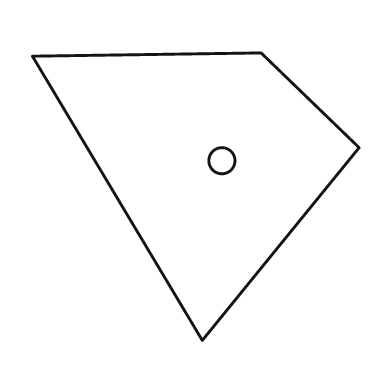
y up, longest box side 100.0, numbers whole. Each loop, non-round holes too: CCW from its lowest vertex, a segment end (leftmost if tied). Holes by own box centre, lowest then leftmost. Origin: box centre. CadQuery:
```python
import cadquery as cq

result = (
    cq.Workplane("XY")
    .moveTo(2.0, -44.0)
    .lineTo(50.0, 15.0)
    .lineTo(20.0, 44.0)
    .lineTo(-50.0, 43.0)
    .close()
    .moveTo(8.0, 11.0)
    .circle(4.0)
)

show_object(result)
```